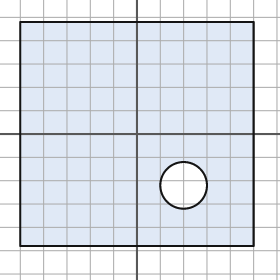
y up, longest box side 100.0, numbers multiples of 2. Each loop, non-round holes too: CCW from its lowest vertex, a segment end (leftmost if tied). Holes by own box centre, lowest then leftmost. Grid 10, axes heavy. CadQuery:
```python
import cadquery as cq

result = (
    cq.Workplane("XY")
    .moveTo(-50.0, -48.0)
    .lineTo(50.0, -48.0)
    .lineTo(50.0, 48.0)
    .lineTo(-50.0, 48.0)
    .close()
    .moveTo(20.0, -22.0)
    .circle(10.0)
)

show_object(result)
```